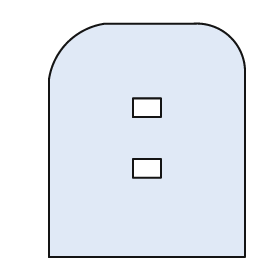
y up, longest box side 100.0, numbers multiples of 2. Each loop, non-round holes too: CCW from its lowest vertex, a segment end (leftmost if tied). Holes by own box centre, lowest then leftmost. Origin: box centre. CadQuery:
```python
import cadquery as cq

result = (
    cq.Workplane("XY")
    .moveTo(-42.0, -50.0)
    .lineTo(42.0, -50.0)
    .lineTo(42.0, 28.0)
    .threePointArc((36.0, 44.0), (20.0, 50.0))
    .lineTo(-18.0, 50.0)
    .threePointArc((-34.0, 42.0), (-42.0, 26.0))
    .close()
    .moveTo(-6.0, -16.0)
    .lineTo(6.0, -16.0)
    .lineTo(6.0, -8.0)
    .lineTo(-6.0, -8.0)
    .close()
    .moveTo(-6.0, 10.0)
    .lineTo(6.0, 10.0)
    .lineTo(6.0, 18.0)
    .lineTo(-6.0, 18.0)
    .close()
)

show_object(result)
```